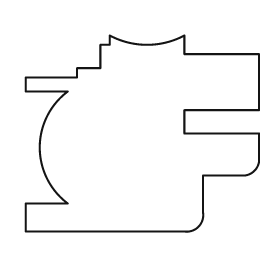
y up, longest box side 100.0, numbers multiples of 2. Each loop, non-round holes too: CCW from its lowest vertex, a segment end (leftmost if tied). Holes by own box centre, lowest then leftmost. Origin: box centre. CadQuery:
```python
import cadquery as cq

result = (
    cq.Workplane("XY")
    .moveTo(-50.0, -42.0)
    .lineTo(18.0, -42.0)
    .threePointArc((24.0, -40.0), (26.0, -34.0))
    .lineTo(26.0, -18.0)
    .lineTo(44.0, -18.0)
    .threePointArc((48.0, -16.0), (50.0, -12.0))
    .lineTo(50.0, 0.0)
    .lineTo(18.0, 0.0)
    .lineTo(18.0, 10.0)
    .lineTo(50.0, 10.0)
    .lineTo(50.0, 34.0)
    .lineTo(18.0, 34.0)
    .lineTo(18.0, 42.0)
    .threePointArc((2.0, 38.0), (-14.0, 42.0))
    .lineTo(-14.0, 38.0)
    .lineTo(-18.0, 38.0)
    .lineTo(-18.0, 28.0)
    .lineTo(-28.0, 28.0)
    .lineTo(-28.0, 24.0)
    .lineTo(-50.0, 24.0)
    .lineTo(-50.0, 18.0)
    .lineTo(-32.0, 18.0)
    .threePointArc((-44.0, -6.0), (-32.0, -30.0))
    .lineTo(-50.0, -30.0)
    .close()
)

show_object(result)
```